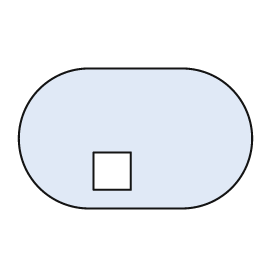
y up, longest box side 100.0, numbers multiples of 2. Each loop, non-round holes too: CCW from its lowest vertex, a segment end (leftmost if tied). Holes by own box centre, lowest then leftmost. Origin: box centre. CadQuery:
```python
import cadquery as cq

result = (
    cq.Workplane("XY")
    .moveTo(-20.0, -30.0)
    .lineTo(20.0, -30.0)
    .threePointArc((50.0, 0.0), (20.0, 30.0))
    .lineTo(-20.0, 30.0)
    .threePointArc((-50.0, 0.0), (-20.0, -30.0))
    .close()
    .moveTo(-18.0, -22.0)
    .lineTo(-2.0, -22.0)
    .lineTo(-2.0, -6.0)
    .lineTo(-18.0, -6.0)
    .close()
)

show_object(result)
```